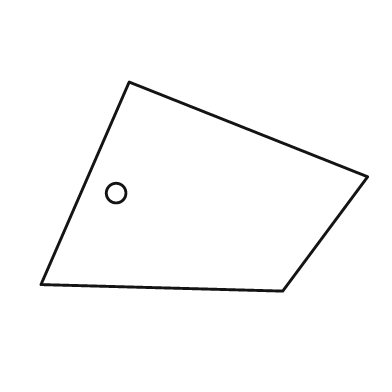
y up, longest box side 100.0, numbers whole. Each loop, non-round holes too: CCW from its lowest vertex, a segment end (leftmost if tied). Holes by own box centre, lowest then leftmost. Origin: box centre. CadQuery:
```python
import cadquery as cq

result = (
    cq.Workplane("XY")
    .moveTo(24.0, -32.0)
    .lineTo(50.0, 3.0)
    .lineTo(-23.0, 32.0)
    .lineTo(-50.0, -30.0)
    .close()
    .moveTo(-27.0, -2.0)
    .circle(3.0)
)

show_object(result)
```